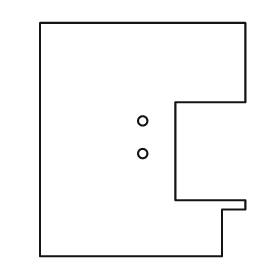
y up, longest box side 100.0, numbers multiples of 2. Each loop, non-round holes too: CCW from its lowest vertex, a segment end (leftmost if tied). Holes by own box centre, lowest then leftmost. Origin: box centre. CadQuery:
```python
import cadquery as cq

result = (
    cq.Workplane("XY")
    .moveTo(-44.0, -50.0)
    .lineTo(34.0, -50.0)
    .lineTo(34.0, -30.0)
    .lineTo(44.0, -30.0)
    .lineTo(44.0, -26.0)
    .lineTo(14.0, -26.0)
    .lineTo(14.0, 16.0)
    .lineTo(44.0, 16.0)
    .lineTo(44.0, 50.0)
    .lineTo(-44.0, 50.0)
    .close()
    .moveTo(0.0, -6.0)
    .circle(2.0)
    .moveTo(0.0, 8.0)
    .circle(2.0)
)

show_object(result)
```